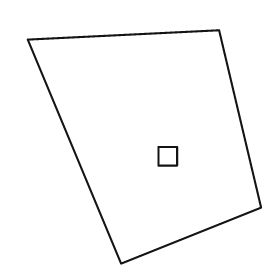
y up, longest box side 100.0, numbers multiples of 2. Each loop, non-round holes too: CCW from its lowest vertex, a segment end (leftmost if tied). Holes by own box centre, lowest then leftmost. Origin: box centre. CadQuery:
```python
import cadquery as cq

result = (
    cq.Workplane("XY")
    .moveTo(-10.0, -50.0)
    .lineTo(50.0, -26.0)
    .lineTo(32.0, 50.0)
    .lineTo(-50.0, 46.0)
    .close()
    .moveTo(6.0, -8.0)
    .lineTo(14.0, -8.0)
    .lineTo(14.0, 0.0)
    .lineTo(6.0, 0.0)
    .close()
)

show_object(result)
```